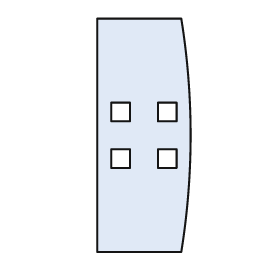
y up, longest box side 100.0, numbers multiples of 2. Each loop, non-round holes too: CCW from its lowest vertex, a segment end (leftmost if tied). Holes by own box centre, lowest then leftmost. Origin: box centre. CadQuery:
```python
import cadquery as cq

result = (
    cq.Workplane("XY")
    .moveTo(-20.0, -50.0)
    .lineTo(16.0, -50.0)
    .threePointArc((20.0, 0.0), (16.0, 50.0))
    .lineTo(-20.0, 50.0)
    .close()
    .moveTo(-14.0, -14.0)
    .lineTo(-6.0, -14.0)
    .lineTo(-6.0, -6.0)
    .lineTo(-14.0, -6.0)
    .close()
    .moveTo(6.0, -14.0)
    .lineTo(14.0, -14.0)
    .lineTo(14.0, -6.0)
    .lineTo(6.0, -6.0)
    .close()
    .moveTo(-14.0, 6.0)
    .lineTo(-6.0, 6.0)
    .lineTo(-6.0, 14.0)
    .lineTo(-14.0, 14.0)
    .close()
    .moveTo(6.0, 6.0)
    .lineTo(14.0, 6.0)
    .lineTo(14.0, 14.0)
    .lineTo(6.0, 14.0)
    .close()
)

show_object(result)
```